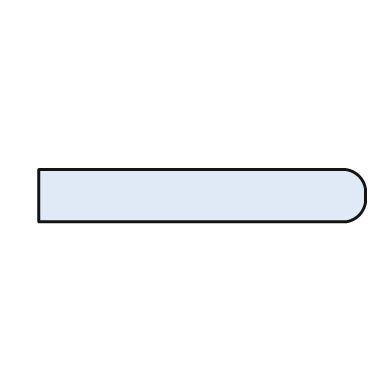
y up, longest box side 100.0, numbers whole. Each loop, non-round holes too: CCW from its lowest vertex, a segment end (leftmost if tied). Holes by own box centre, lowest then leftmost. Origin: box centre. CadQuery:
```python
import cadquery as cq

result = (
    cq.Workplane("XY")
    .moveTo(-50.0, -8.0)
    .lineTo(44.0, -8.0)
    .threePointArc((48.0, -6.0), (50.0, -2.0))
    .lineTo(50.0, 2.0)
    .threePointArc((48.0, 6.0), (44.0, 8.0))
    .lineTo(-50.0, 8.0)
    .close()
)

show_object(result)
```